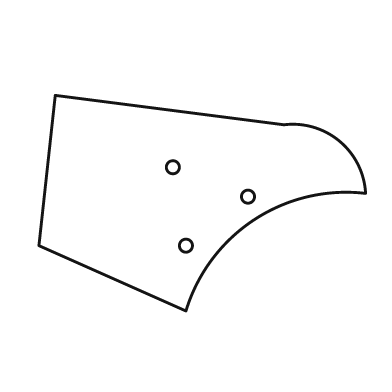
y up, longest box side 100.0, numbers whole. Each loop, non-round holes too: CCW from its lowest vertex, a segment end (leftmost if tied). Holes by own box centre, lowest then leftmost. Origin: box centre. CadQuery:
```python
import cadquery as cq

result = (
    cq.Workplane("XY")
    .moveTo(-5.0, -33.0)
    .threePointArc((16.0, -5.0), (50.0, 3.0))
    .threePointArc((42.0, 19.0), (25.0, 24.0))
    .lineTo(-45.0, 33.0)
    .lineTo(-50.0, -13.0)
    .close()
    .moveTo(-5.0, -13.0)
    .circle(2.0)
    .moveTo(14.0, 2.0)
    .circle(2.0)
    .moveTo(-9.0, 11.0)
    .circle(2.0)
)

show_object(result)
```